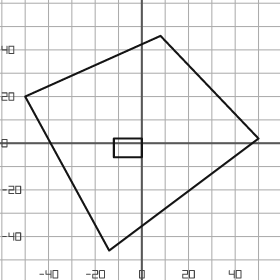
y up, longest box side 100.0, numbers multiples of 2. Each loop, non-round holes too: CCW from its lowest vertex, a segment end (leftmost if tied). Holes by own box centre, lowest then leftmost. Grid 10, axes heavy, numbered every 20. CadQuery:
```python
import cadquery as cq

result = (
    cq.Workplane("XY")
    .moveTo(-14.0, -46.0)
    .lineTo(50.0, 2.0)
    .lineTo(8.0, 46.0)
    .lineTo(-50.0, 20.0)
    .close()
    .moveTo(-12.0, -6.0)
    .lineTo(0.0, -6.0)
    .lineTo(0.0, 2.0)
    .lineTo(-12.0, 2.0)
    .close()
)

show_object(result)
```